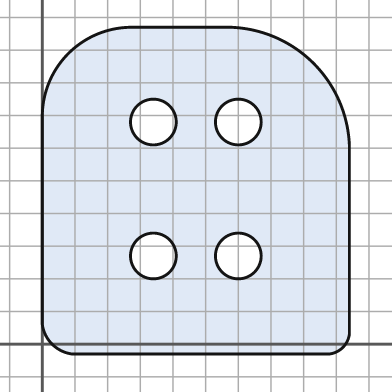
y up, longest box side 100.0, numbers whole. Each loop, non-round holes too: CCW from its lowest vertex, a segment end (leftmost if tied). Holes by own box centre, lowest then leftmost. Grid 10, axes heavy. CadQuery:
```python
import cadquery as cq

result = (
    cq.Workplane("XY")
    .moveTo(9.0, -3.0)
    .lineTo(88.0, -3.0)
    .threePointArc((92.0, -1.0), (94.0, 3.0))
    .lineTo(94.0, 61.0)
    .threePointArc((83.0, 86.0), (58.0, 97.0))
    .lineTo(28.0, 97.0)
    .threePointArc((8.0, 89.0), (0.0, 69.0))
    .lineTo(0.0, 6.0)
    .threePointArc((3.0, 0.0), (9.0, -3.0))
    .close()
    .moveTo(34.0, 27.0)
    .circle(7.0)
    .moveTo(60.0, 27.0)
    .circle(7.0)
    .moveTo(34.0, 68.0)
    .circle(7.0)
    .moveTo(60.0, 68.0)
    .circle(7.0)
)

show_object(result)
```